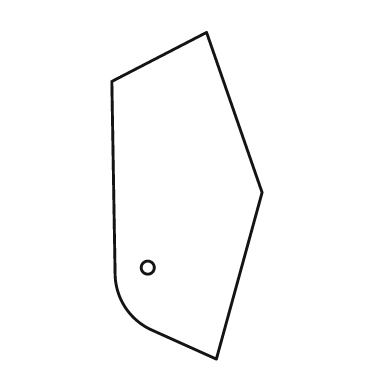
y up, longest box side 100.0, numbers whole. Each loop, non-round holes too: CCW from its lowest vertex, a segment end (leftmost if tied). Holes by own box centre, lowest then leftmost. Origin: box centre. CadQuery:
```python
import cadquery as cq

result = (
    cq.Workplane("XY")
    .moveTo(9.0, -50.0)
    .lineTo(23.0, 1.0)
    .lineTo(6.0, 50.0)
    .lineTo(-23.0, 35.0)
    .lineTo(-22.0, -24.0)
    .threePointArc((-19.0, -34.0), (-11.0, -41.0))
    .close()
    .moveTo(-12.0, -22.0)
    .circle(2.0)
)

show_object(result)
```